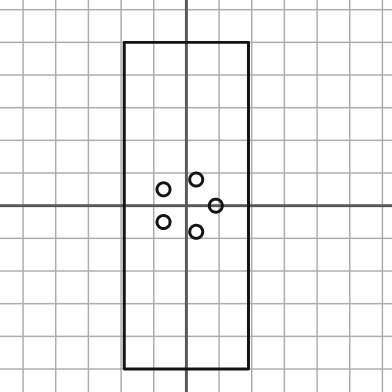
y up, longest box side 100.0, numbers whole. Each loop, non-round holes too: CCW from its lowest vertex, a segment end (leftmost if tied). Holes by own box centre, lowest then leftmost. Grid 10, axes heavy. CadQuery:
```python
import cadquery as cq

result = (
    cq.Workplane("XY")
    .moveTo(-19.0, -50.0)
    .lineTo(19.0, -50.0)
    .lineTo(19.0, 50.0)
    .lineTo(-19.0, 50.0)
    .close()
    .moveTo(3.0, -8.0)
    .circle(2.0)
    .moveTo(-7.0, -5.0)
    .circle(2.0)
    .moveTo(9.0, 0.0)
    .circle(2.0)
    .moveTo(-7.0, 5.0)
    .circle(2.0)
    .moveTo(3.0, 8.0)
    .circle(2.0)
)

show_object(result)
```